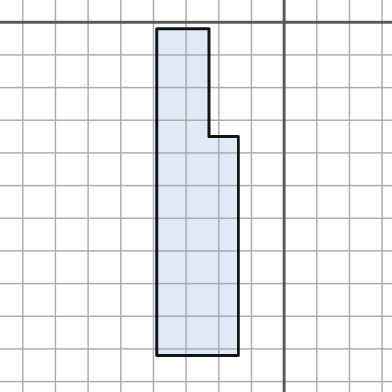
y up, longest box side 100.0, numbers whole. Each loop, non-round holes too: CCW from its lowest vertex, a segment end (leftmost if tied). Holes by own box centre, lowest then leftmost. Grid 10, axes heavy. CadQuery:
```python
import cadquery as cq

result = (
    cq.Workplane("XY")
    .moveTo(-39.0, -102.0)
    .lineTo(-14.0, -102.0)
    .lineTo(-14.0, -35.0)
    .lineTo(-23.0, -35.0)
    .lineTo(-23.0, -2.0)
    .lineTo(-39.0, -2.0)
    .close()
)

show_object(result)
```